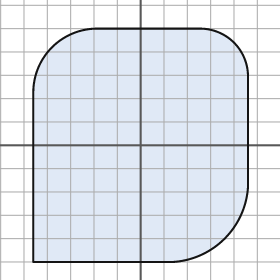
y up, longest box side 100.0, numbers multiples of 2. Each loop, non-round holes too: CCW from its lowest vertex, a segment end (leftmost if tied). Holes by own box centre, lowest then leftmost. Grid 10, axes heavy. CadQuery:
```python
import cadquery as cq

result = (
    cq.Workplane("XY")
    .moveTo(-46.0, -50.0)
    .lineTo(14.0, -50.0)
    .threePointArc((36.0, -40.0), (46.0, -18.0))
    .lineTo(46.0, 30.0)
    .threePointArc((40.0, 44.0), (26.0, 50.0))
    .lineTo(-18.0, 50.0)
    .threePointArc((-38.0, 42.0), (-46.0, 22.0))
    .close()
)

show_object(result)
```